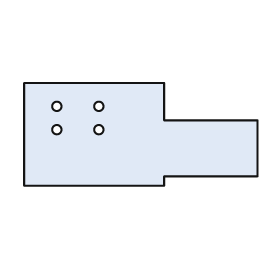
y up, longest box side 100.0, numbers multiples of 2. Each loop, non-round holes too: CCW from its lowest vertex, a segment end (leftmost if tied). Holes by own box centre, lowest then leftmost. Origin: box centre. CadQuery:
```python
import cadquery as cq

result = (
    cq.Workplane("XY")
    .moveTo(-50.0, -22.0)
    .lineTo(10.0, -22.0)
    .lineTo(10.0, -18.0)
    .lineTo(50.0, -18.0)
    .lineTo(50.0, 6.0)
    .lineTo(10.0, 6.0)
    .lineTo(10.0, 22.0)
    .lineTo(-50.0, 22.0)
    .close()
    .moveTo(-36.0, 2.0)
    .circle(2.0)
    .moveTo(-18.0, 2.0)
    .circle(2.0)
    .moveTo(-36.0, 12.0)
    .circle(2.0)
    .moveTo(-18.0, 12.0)
    .circle(2.0)
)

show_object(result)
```